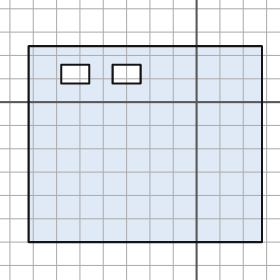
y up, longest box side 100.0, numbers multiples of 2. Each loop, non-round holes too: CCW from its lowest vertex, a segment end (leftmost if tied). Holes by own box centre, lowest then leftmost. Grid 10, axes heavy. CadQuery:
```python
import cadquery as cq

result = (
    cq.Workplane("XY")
    .moveTo(-72.0, -60.0)
    .lineTo(28.0, -60.0)
    .lineTo(28.0, 24.0)
    .lineTo(-72.0, 24.0)
    .close()
    .moveTo(-58.0, 8.0)
    .lineTo(-46.0, 8.0)
    .lineTo(-46.0, 16.0)
    .lineTo(-58.0, 16.0)
    .close()
    .moveTo(-36.0, 8.0)
    .lineTo(-24.0, 8.0)
    .lineTo(-24.0, 16.0)
    .lineTo(-36.0, 16.0)
    .close()
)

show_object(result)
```